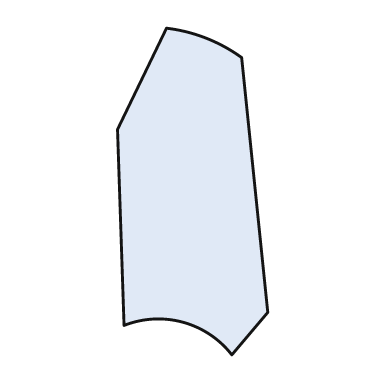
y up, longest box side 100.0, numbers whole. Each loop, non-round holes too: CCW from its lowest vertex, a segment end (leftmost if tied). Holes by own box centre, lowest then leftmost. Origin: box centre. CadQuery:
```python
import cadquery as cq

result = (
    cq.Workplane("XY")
    .moveTo(12.0, -50.0)
    .lineTo(23.0, -37.0)
    .lineTo(15.0, 41.0)
    .threePointArc((4.0, 47.0), (-8.0, 50.0))
    .lineTo(-23.0, 19.0)
    .lineTo(-21.0, -41.0)
    .threePointArc((-3.0, -40.0), (12.0, -50.0))
    .close()
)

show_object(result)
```